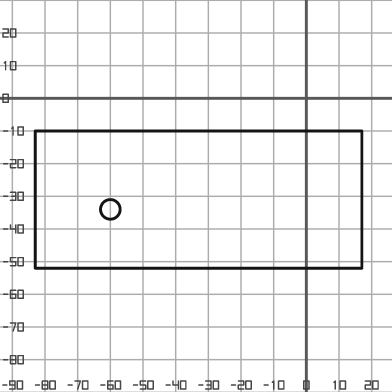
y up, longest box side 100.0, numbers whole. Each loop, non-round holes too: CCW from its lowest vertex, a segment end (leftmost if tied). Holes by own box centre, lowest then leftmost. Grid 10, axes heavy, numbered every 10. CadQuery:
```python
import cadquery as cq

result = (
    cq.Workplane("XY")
    .moveTo(-83.0, -52.0)
    .lineTo(17.0, -52.0)
    .lineTo(17.0, -10.0)
    .lineTo(-83.0, -10.0)
    .close()
    .moveTo(-60.0, -34.0)
    .circle(3.0)
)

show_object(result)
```